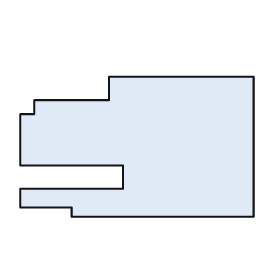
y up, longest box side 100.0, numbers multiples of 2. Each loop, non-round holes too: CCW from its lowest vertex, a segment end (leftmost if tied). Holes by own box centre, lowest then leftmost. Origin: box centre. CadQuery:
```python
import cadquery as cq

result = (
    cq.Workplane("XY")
    .moveTo(-28.0, -30.0)
    .lineTo(50.0, -30.0)
    .lineTo(50.0, 30.0)
    .lineTo(-12.0, 30.0)
    .lineTo(-12.0, 20.0)
    .lineTo(-44.0, 20.0)
    .lineTo(-44.0, 14.0)
    .lineTo(-50.0, 14.0)
    .lineTo(-50.0, -8.0)
    .lineTo(-6.0, -8.0)
    .lineTo(-6.0, -18.0)
    .lineTo(-50.0, -18.0)
    .lineTo(-50.0, -26.0)
    .lineTo(-28.0, -26.0)
    .close()
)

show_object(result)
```